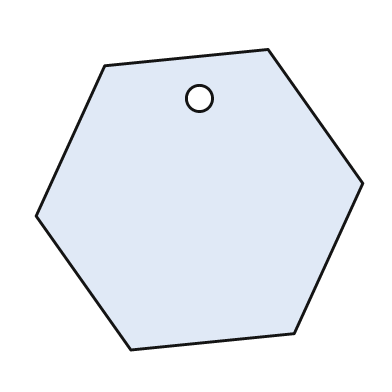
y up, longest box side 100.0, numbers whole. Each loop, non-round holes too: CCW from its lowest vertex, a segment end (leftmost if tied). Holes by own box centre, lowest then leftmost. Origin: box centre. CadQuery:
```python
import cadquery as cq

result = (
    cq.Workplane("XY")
    .moveTo(-21.0, -46.0)
    .lineTo(29.0, -41.0)
    .lineTo(50.0, 5.0)
    .lineTo(21.0, 46.0)
    .lineTo(-29.0, 41.0)
    .lineTo(-50.0, -5.0)
    .close()
    .moveTo(0.0, 31.0)
    .circle(4.0)
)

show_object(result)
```